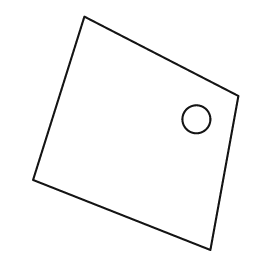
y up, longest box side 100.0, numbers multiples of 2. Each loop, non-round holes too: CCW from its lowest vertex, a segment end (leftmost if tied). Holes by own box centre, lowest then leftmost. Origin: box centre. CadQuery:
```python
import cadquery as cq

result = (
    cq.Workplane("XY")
    .moveTo(32.0, -50.0)
    .lineTo(44.0, 16.0)
    .lineTo(-22.0, 50.0)
    .lineTo(-44.0, -20.0)
    .close()
    .moveTo(26.0, 6.0)
    .circle(6.0)
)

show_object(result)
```